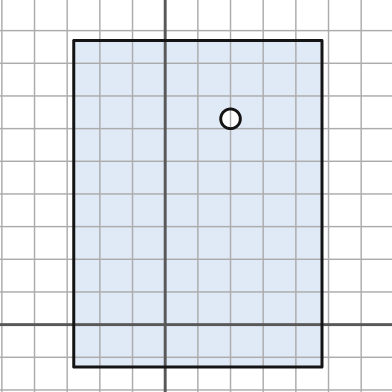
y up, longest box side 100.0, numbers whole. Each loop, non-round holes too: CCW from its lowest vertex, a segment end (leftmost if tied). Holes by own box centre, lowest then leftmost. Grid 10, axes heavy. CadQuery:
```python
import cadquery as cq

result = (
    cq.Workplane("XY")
    .moveTo(-28.0, -13.0)
    .lineTo(48.0, -13.0)
    .lineTo(48.0, 87.0)
    .lineTo(-28.0, 87.0)
    .close()
    .moveTo(20.0, 63.0)
    .circle(3.0)
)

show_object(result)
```